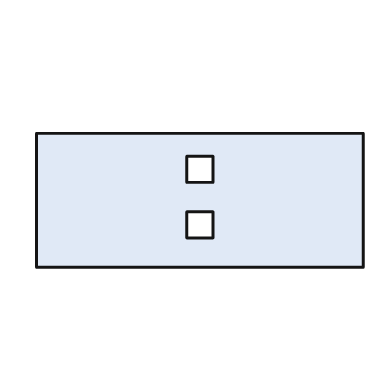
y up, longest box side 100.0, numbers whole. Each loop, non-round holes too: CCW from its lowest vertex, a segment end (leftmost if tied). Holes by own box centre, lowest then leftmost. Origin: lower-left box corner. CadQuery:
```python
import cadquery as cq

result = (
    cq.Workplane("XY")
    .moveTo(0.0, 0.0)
    .lineTo(100.0, 0.0)
    .lineTo(100.0, 41.0)
    .lineTo(0.0, 41.0)
    .close()
    .moveTo(46.0, 9.0)
    .lineTo(54.0, 9.0)
    .lineTo(54.0, 17.0)
    .lineTo(46.0, 17.0)
    .close()
    .moveTo(46.0, 26.0)
    .lineTo(54.0, 26.0)
    .lineTo(54.0, 34.0)
    .lineTo(46.0, 34.0)
    .close()
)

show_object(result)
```